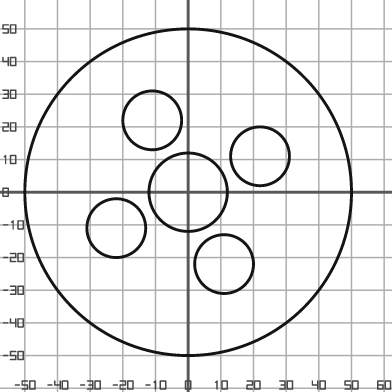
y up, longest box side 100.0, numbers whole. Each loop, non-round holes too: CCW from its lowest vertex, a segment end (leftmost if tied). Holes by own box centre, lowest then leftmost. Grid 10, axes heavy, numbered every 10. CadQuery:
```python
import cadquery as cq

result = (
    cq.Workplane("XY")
    .moveTo(0.0, 0.0)
    .circle(50.0)
    .moveTo(11.0, -22.0)
    .circle(9.0)
    .moveTo(-22.0, -11.0)
    .circle(9.0)
    .moveTo(0.0, 0.0)
    .circle(12.0)
    .moveTo(22.0, 11.0)
    .circle(9.0)
    .moveTo(-11.0, 22.0)
    .circle(9.0)
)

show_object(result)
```